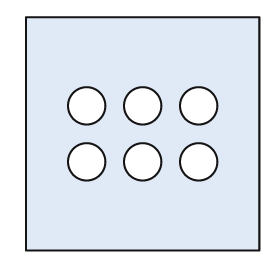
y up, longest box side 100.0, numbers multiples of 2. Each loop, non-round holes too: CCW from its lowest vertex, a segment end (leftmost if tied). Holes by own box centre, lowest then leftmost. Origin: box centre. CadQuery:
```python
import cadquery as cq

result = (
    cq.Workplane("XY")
    .moveTo(-50.0, -50.0)
    .lineTo(50.0, -50.0)
    .lineTo(50.0, 50.0)
    .lineTo(-50.0, 50.0)
    .close()
    .moveTo(-24.0, -12.0)
    .circle(8.0)
    .moveTo(0.0, -12.0)
    .circle(8.0)
    .moveTo(24.0, -12.0)
    .circle(8.0)
    .moveTo(-24.0, 12.0)
    .circle(8.0)
    .moveTo(0.0, 12.0)
    .circle(8.0)
    .moveTo(24.0, 12.0)
    .circle(8.0)
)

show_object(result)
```